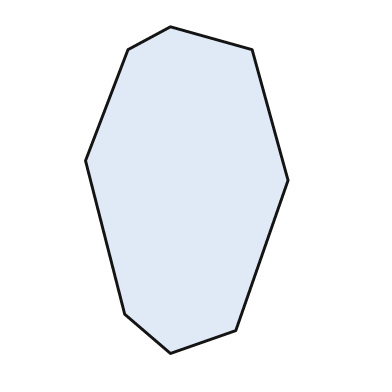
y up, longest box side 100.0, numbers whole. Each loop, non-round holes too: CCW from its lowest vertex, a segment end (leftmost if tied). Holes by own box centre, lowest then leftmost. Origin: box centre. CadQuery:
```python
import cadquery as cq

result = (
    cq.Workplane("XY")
    .moveTo(-5.0, -50.0)
    .lineTo(15.0, -43.0)
    .lineTo(31.0, 3.0)
    .lineTo(20.0, 43.0)
    .lineTo(-5.0, 50.0)
    .lineTo(-18.0, 43.0)
    .lineTo(-31.0, 9.0)
    .lineTo(-19.0, -38.0)
    .close()
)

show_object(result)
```